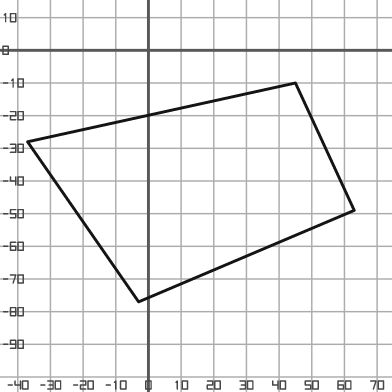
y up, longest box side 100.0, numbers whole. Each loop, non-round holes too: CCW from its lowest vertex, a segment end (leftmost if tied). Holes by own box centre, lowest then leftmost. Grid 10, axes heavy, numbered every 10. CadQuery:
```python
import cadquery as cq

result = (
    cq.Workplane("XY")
    .moveTo(-3.0, -77.0)
    .lineTo(63.0, -49.0)
    .lineTo(45.0, -10.0)
    .lineTo(-37.0, -28.0)
    .close()
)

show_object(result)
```